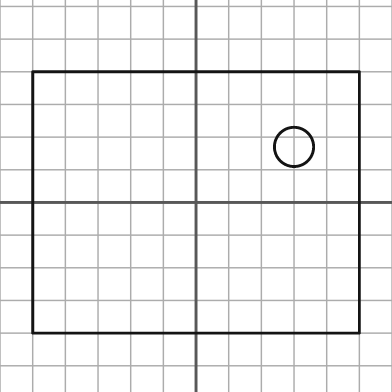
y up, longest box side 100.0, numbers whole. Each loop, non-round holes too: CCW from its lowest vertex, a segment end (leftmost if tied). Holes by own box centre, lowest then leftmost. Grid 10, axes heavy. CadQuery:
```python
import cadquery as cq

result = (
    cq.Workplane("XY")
    .moveTo(-50.0, -40.0)
    .lineTo(50.0, -40.0)
    .lineTo(50.0, 40.0)
    .lineTo(-50.0, 40.0)
    .close()
    .moveTo(30.0, 17.0)
    .circle(6.0)
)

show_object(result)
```